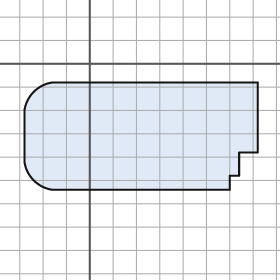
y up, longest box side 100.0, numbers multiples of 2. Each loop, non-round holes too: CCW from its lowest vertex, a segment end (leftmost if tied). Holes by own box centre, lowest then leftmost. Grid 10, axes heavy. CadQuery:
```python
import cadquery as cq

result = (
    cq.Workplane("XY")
    .moveTo(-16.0, -54.0)
    .lineTo(60.0, -54.0)
    .lineTo(60.0, -48.0)
    .lineTo(64.0, -48.0)
    .lineTo(64.0, -38.0)
    .lineTo(72.0, -38.0)
    .lineTo(72.0, -8.0)
    .lineTo(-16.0, -8.0)
    .threePointArc((-24.0, -12.0), (-28.0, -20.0))
    .lineTo(-28.0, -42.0)
    .threePointArc((-24.0, -50.0), (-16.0, -54.0))
    .close()
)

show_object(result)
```